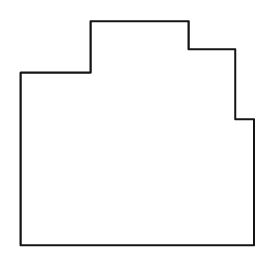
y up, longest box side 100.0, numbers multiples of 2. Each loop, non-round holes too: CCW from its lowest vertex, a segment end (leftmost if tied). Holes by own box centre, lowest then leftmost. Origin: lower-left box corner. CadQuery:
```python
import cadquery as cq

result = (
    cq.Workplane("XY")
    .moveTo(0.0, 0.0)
    .lineTo(100.0, 0.0)
    .lineTo(100.0, 54.0)
    .lineTo(92.0, 54.0)
    .lineTo(92.0, 84.0)
    .lineTo(72.0, 84.0)
    .lineTo(72.0, 96.0)
    .lineTo(30.0, 96.0)
    .lineTo(30.0, 74.0)
    .lineTo(0.0, 74.0)
    .close()
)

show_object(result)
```